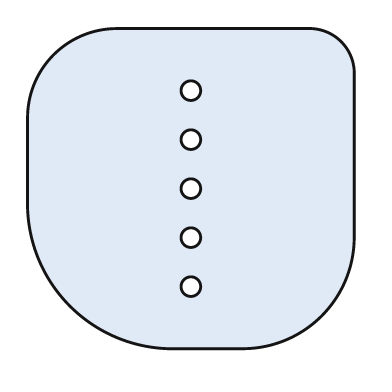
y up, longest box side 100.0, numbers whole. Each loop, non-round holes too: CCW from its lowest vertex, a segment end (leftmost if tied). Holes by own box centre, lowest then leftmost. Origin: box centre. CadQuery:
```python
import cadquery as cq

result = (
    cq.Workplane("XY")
    .moveTo(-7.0, -49.0)
    .lineTo(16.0, -49.0)
    .threePointArc((40.0, -39.0), (50.0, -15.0))
    .lineTo(50.0, 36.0)
    .threePointArc((46.0, 45.0), (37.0, 49.0))
    .lineTo(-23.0, 49.0)
    .threePointArc((-42.0, 41.0), (-50.0, 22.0))
    .lineTo(-50.0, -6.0)
    .threePointArc((-37.0, -36.0), (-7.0, -49.0))
    .close()
    .moveTo(0.0, -30.0)
    .circle(3.0)
    .moveTo(0.0, -15.0)
    .circle(3.0)
    .moveTo(0.0, 0.0)
    .circle(3.0)
    .moveTo(0.0, 15.0)
    .circle(3.0)
    .moveTo(0.0, 30.0)
    .circle(3.0)
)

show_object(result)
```